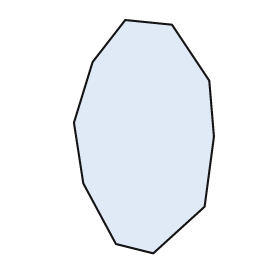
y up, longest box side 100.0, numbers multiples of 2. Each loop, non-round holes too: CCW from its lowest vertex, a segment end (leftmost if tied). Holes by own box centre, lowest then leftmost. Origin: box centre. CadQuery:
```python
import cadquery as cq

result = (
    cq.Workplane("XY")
    .moveTo(4.0, -50.0)
    .lineTo(26.0, -30.0)
    .lineTo(30.0, 0.0)
    .lineTo(28.0, 24.0)
    .lineTo(12.0, 48.0)
    .lineTo(-8.0, 50.0)
    .lineTo(-22.0, 32.0)
    .lineTo(-30.0, 6.0)
    .lineTo(-26.0, -20.0)
    .lineTo(-12.0, -46.0)
    .close()
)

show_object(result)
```